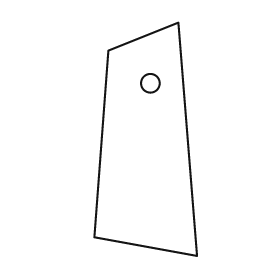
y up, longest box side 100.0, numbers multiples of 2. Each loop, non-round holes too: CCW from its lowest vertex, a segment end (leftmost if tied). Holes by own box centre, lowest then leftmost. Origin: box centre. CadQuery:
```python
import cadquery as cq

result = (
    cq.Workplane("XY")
    .moveTo(22.0, -50.0)
    .lineTo(14.0, 50.0)
    .lineTo(-16.0, 38.0)
    .lineTo(-22.0, -42.0)
    .close()
    .moveTo(2.0, 24.0)
    .circle(4.0)
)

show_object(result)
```